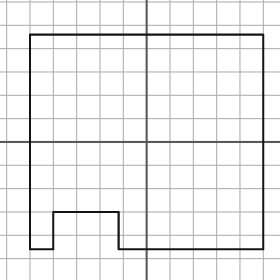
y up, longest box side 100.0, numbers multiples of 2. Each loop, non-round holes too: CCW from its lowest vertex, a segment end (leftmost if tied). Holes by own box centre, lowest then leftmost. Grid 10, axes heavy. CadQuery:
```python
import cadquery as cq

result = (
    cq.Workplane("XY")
    .moveTo(-50.0, -46.0)
    .lineTo(-40.0, -46.0)
    .lineTo(-40.0, -30.0)
    .lineTo(-12.0, -30.0)
    .lineTo(-12.0, -46.0)
    .lineTo(50.0, -46.0)
    .lineTo(50.0, 46.0)
    .lineTo(-50.0, 46.0)
    .close()
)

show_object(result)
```